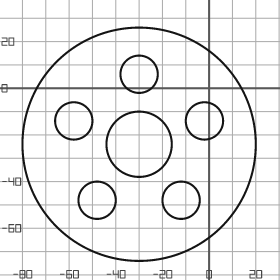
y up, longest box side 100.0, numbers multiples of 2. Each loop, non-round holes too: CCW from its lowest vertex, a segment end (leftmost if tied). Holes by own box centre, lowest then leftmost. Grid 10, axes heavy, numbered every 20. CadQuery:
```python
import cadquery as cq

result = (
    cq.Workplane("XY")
    .moveTo(-30.0, -24.0)
    .circle(50.0)
    .moveTo(-48.0, -48.0)
    .circle(8.0)
    .moveTo(-12.0, -48.0)
    .circle(8.0)
    .moveTo(-30.0, -24.0)
    .circle(14.0)
    .moveTo(-58.0, -14.0)
    .circle(8.0)
    .moveTo(-2.0, -14.0)
    .circle(8.0)
    .moveTo(-30.0, 6.0)
    .circle(8.0)
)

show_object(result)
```